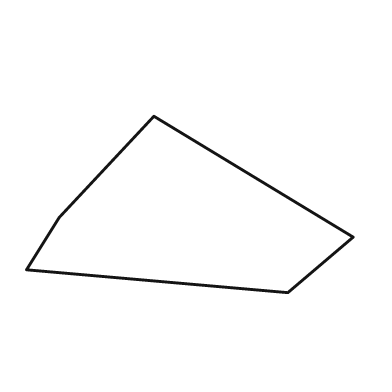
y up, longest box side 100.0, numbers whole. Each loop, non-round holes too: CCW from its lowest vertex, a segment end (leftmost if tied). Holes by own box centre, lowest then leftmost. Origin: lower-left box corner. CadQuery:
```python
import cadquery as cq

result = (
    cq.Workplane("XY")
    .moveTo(80.0, 0.0)
    .lineTo(100.0, 17.0)
    .lineTo(39.0, 54.0)
    .lineTo(10.0, 23.0)
    .lineTo(0.0, 7.0)
    .close()
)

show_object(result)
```